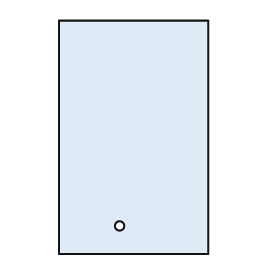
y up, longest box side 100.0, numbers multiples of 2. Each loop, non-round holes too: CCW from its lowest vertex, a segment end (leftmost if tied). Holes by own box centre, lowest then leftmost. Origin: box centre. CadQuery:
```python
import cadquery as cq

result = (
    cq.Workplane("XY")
    .moveTo(-32.0, -50.0)
    .lineTo(32.0, -50.0)
    .lineTo(32.0, 50.0)
    .lineTo(-32.0, 50.0)
    .close()
    .moveTo(-6.0, -38.0)
    .circle(2.0)
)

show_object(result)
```